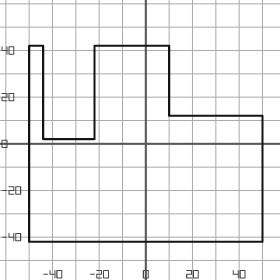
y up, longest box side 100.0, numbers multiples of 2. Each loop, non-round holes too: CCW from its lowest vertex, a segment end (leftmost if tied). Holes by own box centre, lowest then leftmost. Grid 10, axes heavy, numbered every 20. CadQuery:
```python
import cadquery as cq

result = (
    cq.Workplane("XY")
    .moveTo(-50.0, -42.0)
    .lineTo(50.0, -42.0)
    .lineTo(50.0, 12.0)
    .lineTo(10.0, 12.0)
    .lineTo(10.0, 42.0)
    .lineTo(-22.0, 42.0)
    .lineTo(-22.0, 2.0)
    .lineTo(-44.0, 2.0)
    .lineTo(-44.0, 42.0)
    .lineTo(-50.0, 42.0)
    .close()
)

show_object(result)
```